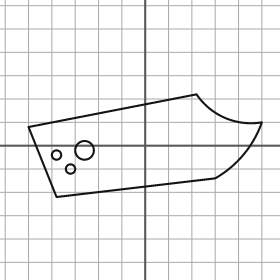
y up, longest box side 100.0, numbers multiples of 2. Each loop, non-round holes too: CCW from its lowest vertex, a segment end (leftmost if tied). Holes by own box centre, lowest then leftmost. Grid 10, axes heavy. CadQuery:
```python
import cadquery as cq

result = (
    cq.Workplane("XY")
    .moveTo(-38.0, -22.0)
    .lineTo(30.0, -14.0)
    .threePointArc((42.0, -4.0), (50.0, 10.0))
    .threePointArc((34.0, 12.0), (22.0, 22.0))
    .lineTo(-50.0, 8.0)
    .close()
    .moveTo(-32.0, -10.0)
    .circle(2.0)
    .moveTo(-38.0, -4.0)
    .circle(2.0)
    .moveTo(-26.0, -2.0)
    .circle(4.0)
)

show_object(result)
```